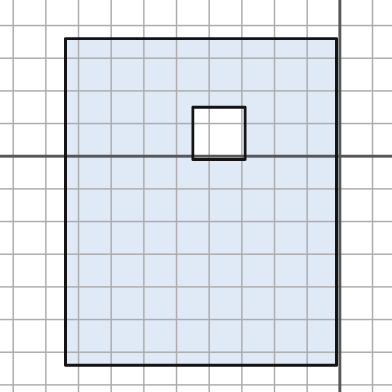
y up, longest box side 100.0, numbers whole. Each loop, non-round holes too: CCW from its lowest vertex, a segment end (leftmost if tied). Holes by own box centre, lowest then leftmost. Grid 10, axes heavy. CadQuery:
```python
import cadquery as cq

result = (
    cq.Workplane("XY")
    .moveTo(-84.0, -64.0)
    .lineTo(-1.0, -64.0)
    .lineTo(-1.0, 36.0)
    .lineTo(-84.0, 36.0)
    .close()
    .moveTo(-45.0, -1.0)
    .lineTo(-29.0, -1.0)
    .lineTo(-29.0, 15.0)
    .lineTo(-45.0, 15.0)
    .close()
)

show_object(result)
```